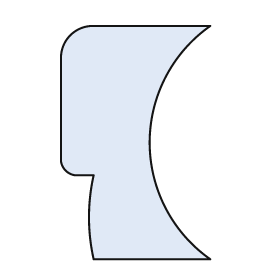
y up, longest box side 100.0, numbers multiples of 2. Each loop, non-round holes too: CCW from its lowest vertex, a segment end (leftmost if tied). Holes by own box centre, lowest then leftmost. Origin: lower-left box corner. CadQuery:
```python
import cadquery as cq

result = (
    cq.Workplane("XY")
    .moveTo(14.0, 0.0)
    .lineTo(64.0, 0.0)
    .threePointArc((38.0, 50.0), (64.0, 100.0))
    .lineTo(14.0, 100.0)
    .threePointArc((4.0, 96.0), (0.0, 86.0))
    .lineTo(0.0, 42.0)
    .threePointArc((2.0, 38.0), (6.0, 36.0))
    .lineTo(14.0, 36.0)
    .threePointArc((12.0, 18.0), (14.0, 0.0))
    .close()
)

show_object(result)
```